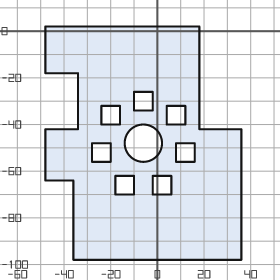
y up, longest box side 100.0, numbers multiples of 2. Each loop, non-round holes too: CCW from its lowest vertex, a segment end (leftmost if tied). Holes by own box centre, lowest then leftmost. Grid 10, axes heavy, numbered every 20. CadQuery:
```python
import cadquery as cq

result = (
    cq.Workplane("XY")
    .moveTo(-36.0, -98.0)
    .lineTo(36.0, -98.0)
    .lineTo(36.0, -42.0)
    .lineTo(18.0, -42.0)
    .lineTo(18.0, 2.0)
    .lineTo(-48.0, 2.0)
    .lineTo(-48.0, -18.0)
    .lineTo(-34.0, -18.0)
    .lineTo(-34.0, -42.0)
    .lineTo(-48.0, -42.0)
    .lineTo(-48.0, -64.0)
    .lineTo(-36.0, -64.0)
    .close()
    .moveTo(-18.0, -70.0)
    .lineTo(-10.0, -70.0)
    .lineTo(-10.0, -62.0)
    .lineTo(-18.0, -62.0)
    .close()
    .moveTo(-2.0, -70.0)
    .lineTo(6.0, -70.0)
    .lineTo(6.0, -62.0)
    .lineTo(-2.0, -62.0)
    .close()
    .moveTo(-28.0, -56.0)
    .lineTo(-20.0, -56.0)
    .lineTo(-20.0, -48.0)
    .lineTo(-28.0, -48.0)
    .close()
    .moveTo(8.0, -56.0)
    .lineTo(16.0, -56.0)
    .lineTo(16.0, -48.0)
    .lineTo(8.0, -48.0)
    .close()
    .moveTo(-6.0, -48.0)
    .circle(8.0)
    .moveTo(-24.0, -40.0)
    .lineTo(-16.0, -40.0)
    .lineTo(-16.0, -32.0)
    .lineTo(-24.0, -32.0)
    .close()
    .moveTo(4.0, -40.0)
    .lineTo(12.0, -40.0)
    .lineTo(12.0, -32.0)
    .lineTo(4.0, -32.0)
    .close()
    .moveTo(-10.0, -34.0)
    .lineTo(-2.0, -34.0)
    .lineTo(-2.0, -26.0)
    .lineTo(-10.0, -26.0)
    .close()
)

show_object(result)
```